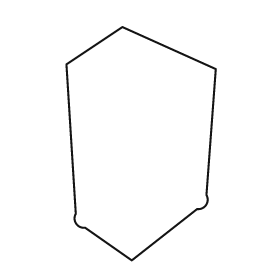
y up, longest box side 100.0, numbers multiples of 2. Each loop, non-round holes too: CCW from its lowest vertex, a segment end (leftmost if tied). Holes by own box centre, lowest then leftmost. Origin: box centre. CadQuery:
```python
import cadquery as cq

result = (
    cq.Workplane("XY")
    .moveTo(-4.0, -50.0)
    .lineTo(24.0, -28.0)
    .threePointArc((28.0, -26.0), (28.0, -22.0))
    .lineTo(32.0, 32.0)
    .lineTo(-8.0, 50.0)
    .lineTo(-32.0, 34.0)
    .lineTo(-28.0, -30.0)
    .threePointArc((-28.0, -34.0), (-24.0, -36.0))
    .close()
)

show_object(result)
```